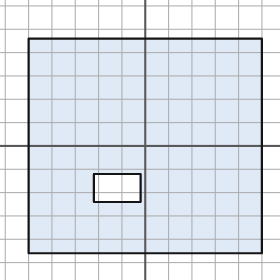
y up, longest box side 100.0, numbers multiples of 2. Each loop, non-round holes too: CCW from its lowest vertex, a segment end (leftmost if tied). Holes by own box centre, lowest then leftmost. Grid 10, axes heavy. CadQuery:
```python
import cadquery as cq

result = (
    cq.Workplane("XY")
    .moveTo(-50.0, -46.0)
    .lineTo(50.0, -46.0)
    .lineTo(50.0, 46.0)
    .lineTo(-50.0, 46.0)
    .close()
    .moveTo(-22.0, -24.0)
    .lineTo(-2.0, -24.0)
    .lineTo(-2.0, -12.0)
    .lineTo(-22.0, -12.0)
    .close()
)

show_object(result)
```